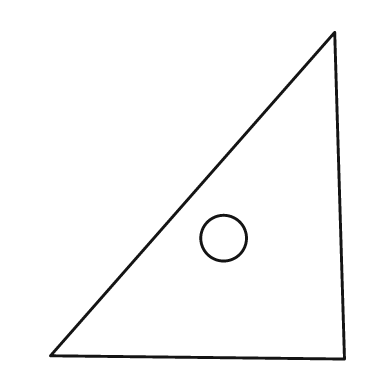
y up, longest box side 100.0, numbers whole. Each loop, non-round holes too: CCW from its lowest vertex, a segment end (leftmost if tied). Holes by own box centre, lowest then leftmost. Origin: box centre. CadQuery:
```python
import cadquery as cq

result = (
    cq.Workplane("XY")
    .moveTo(45.0, -50.0)
    .lineTo(42.0, 50.0)
    .lineTo(-45.0, -49.0)
    .close()
    .moveTo(8.0, -13.0)
    .circle(7.0)
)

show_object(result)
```